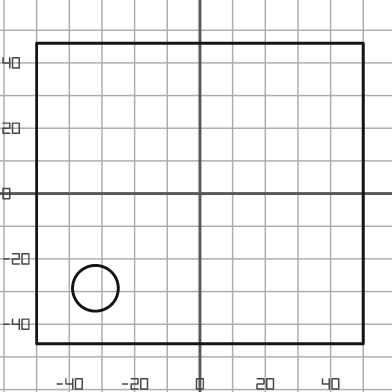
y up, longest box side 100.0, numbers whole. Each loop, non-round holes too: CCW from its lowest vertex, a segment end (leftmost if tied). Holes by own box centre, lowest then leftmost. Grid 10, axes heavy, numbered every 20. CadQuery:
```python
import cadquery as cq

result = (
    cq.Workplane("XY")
    .moveTo(-50.0, -46.0)
    .lineTo(50.0, -46.0)
    .lineTo(50.0, 46.0)
    .lineTo(-50.0, 46.0)
    .close()
    .moveTo(-32.0, -29.0)
    .circle(7.0)
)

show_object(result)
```